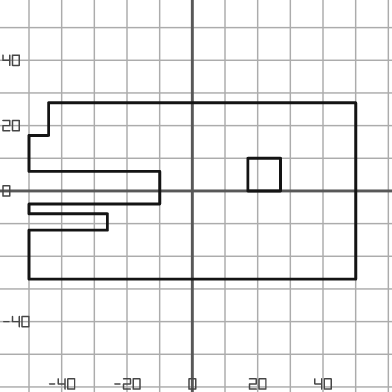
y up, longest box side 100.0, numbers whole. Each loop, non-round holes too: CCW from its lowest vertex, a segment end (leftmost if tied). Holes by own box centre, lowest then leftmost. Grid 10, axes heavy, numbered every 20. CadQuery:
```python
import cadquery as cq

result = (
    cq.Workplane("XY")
    .moveTo(-50.0, -27.0)
    .lineTo(50.0, -27.0)
    .lineTo(50.0, 27.0)
    .lineTo(-44.0, 27.0)
    .lineTo(-44.0, 17.0)
    .lineTo(-50.0, 17.0)
    .lineTo(-50.0, 6.0)
    .lineTo(-10.0, 6.0)
    .lineTo(-10.0, -4.0)
    .lineTo(-50.0, -4.0)
    .lineTo(-50.0, -7.0)
    .lineTo(-26.0, -7.0)
    .lineTo(-26.0, -12.0)
    .lineTo(-50.0, -12.0)
    .close()
    .moveTo(17.0, 0.0)
    .lineTo(27.0, 0.0)
    .lineTo(27.0, 10.0)
    .lineTo(17.0, 10.0)
    .close()
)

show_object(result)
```